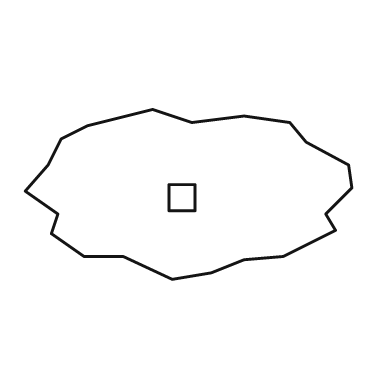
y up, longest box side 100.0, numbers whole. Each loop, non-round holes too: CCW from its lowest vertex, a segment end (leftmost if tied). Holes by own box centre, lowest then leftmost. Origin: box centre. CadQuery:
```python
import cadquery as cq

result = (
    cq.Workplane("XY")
    .moveTo(-5.0, -26.0)
    .lineTo(7.0, -24.0)
    .lineTo(17.0, -20.0)
    .lineTo(29.0, -19.0)
    .lineTo(45.0, -11.0)
    .lineTo(42.0, -6.0)
    .lineTo(50.0, 2.0)
    .lineTo(49.0, 9.0)
    .lineTo(36.0, 16.0)
    .lineTo(31.0, 22.0)
    .lineTo(17.0, 24.0)
    .lineTo(1.0, 22.0)
    .lineTo(-11.0, 26.0)
    .lineTo(-31.0, 21.0)
    .lineTo(-39.0, 17.0)
    .lineTo(-43.0, 9.0)
    .lineTo(-50.0, 1.0)
    .lineTo(-40.0, -6.0)
    .lineTo(-42.0, -12.0)
    .lineTo(-32.0, -19.0)
    .lineTo(-20.0, -19.0)
    .close()
    .moveTo(-6.0, -5.0)
    .lineTo(2.0, -5.0)
    .lineTo(2.0, 3.0)
    .lineTo(-6.0, 3.0)
    .close()
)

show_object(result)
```